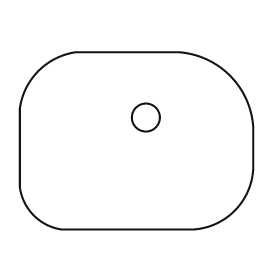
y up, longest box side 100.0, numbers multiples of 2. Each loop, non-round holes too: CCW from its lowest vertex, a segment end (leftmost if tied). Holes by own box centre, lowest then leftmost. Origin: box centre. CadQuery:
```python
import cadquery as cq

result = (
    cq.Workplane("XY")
    .moveTo(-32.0, -38.0)
    .lineTo(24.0, -38.0)
    .threePointArc((42.0, -30.0), (50.0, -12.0))
    .lineTo(50.0, 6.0)
    .threePointArc((40.0, 28.0), (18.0, 38.0))
    .lineTo(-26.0, 38.0)
    .threePointArc((-42.0, 30.0), (-50.0, 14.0))
    .lineTo(-50.0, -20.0)
    .threePointArc((-44.0, -32.0), (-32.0, -38.0))
    .close()
    .moveTo(4.0, 10.0)
    .circle(6.0)
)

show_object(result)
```